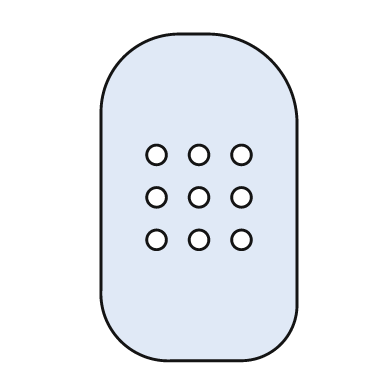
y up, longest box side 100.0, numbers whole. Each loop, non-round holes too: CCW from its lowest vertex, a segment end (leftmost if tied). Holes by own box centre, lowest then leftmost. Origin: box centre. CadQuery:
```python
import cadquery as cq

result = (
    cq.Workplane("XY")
    .moveTo(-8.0, -50.0)
    .lineTo(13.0, -50.0)
    .threePointArc((25.0, -45.0), (30.0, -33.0))
    .lineTo(30.0, 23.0)
    .threePointArc((22.0, 42.0), (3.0, 50.0))
    .lineTo(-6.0, 50.0)
    .threePointArc((-23.0, 43.0), (-30.0, 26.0))
    .lineTo(-30.0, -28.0)
    .threePointArc((-24.0, -44.0), (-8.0, -50.0))
    .close()
    .moveTo(-13.0, -13.0)
    .circle(3.0)
    .moveTo(0.0, -13.0)
    .circle(3.0)
    .moveTo(13.0, -13.0)
    .circle(3.0)
    .moveTo(-13.0, 0.0)
    .circle(3.0)
    .moveTo(0.0, 0.0)
    .circle(3.0)
    .moveTo(13.0, 0.0)
    .circle(3.0)
    .moveTo(-13.0, 13.0)
    .circle(3.0)
    .moveTo(0.0, 13.0)
    .circle(3.0)
    .moveTo(13.0, 13.0)
    .circle(3.0)
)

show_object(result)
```